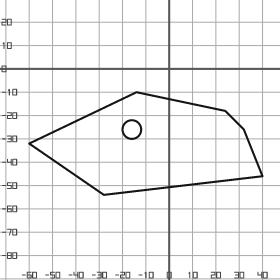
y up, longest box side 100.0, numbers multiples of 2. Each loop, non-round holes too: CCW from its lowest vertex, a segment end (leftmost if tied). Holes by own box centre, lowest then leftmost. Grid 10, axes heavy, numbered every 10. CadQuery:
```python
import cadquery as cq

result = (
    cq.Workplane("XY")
    .moveTo(-28.0, -54.0)
    .lineTo(40.0, -46.0)
    .lineTo(32.0, -26.0)
    .lineTo(24.0, -18.0)
    .lineTo(-14.0, -10.0)
    .lineTo(-60.0, -32.0)
    .close()
    .moveTo(-16.0, -26.0)
    .circle(4.0)
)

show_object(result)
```